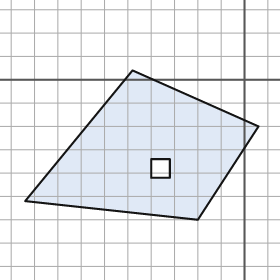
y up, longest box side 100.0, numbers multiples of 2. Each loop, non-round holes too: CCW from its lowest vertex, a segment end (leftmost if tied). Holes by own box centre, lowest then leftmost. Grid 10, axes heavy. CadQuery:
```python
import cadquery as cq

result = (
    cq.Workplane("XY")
    .moveTo(-20.0, -60.0)
    .lineTo(6.0, -20.0)
    .lineTo(-48.0, 4.0)
    .lineTo(-94.0, -52.0)
    .close()
    .moveTo(-40.0, -42.0)
    .lineTo(-32.0, -42.0)
    .lineTo(-32.0, -34.0)
    .lineTo(-40.0, -34.0)
    .close()
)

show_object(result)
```